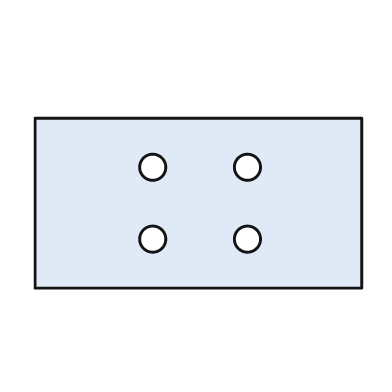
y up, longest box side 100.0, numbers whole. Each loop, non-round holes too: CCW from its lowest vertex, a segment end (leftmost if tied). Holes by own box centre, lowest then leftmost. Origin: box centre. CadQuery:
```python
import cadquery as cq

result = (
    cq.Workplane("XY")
    .moveTo(-50.0, -26.0)
    .lineTo(50.0, -26.0)
    .lineTo(50.0, 26.0)
    .lineTo(-50.0, 26.0)
    .close()
    .moveTo(-14.0, -11.0)
    .circle(4.0)
    .moveTo(15.0, -11.0)
    .circle(4.0)
    .moveTo(-14.0, 11.0)
    .circle(4.0)
    .moveTo(15.0, 11.0)
    .circle(4.0)
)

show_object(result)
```